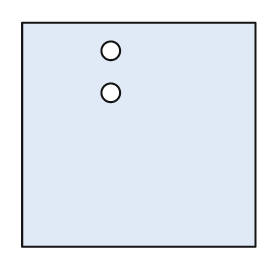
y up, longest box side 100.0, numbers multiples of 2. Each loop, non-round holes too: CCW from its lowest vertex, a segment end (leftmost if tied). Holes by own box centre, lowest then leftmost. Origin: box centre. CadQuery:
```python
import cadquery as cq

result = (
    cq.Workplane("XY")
    .moveTo(-50.0, -48.0)
    .lineTo(50.0, -48.0)
    .lineTo(50.0, 48.0)
    .lineTo(-50.0, 48.0)
    .close()
    .moveTo(-12.0, 18.0)
    .circle(4.0)
    .moveTo(-12.0, 36.0)
    .circle(4.0)
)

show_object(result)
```